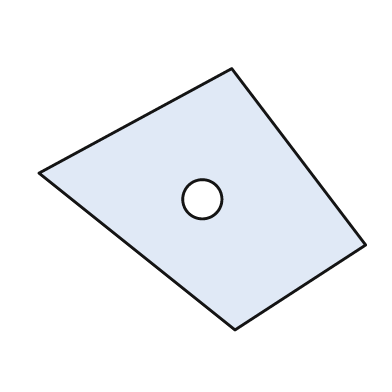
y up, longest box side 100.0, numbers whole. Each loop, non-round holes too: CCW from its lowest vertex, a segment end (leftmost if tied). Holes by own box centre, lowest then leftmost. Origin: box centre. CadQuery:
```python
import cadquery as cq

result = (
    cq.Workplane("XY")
    .moveTo(10.0, -40.0)
    .lineTo(50.0, -14.0)
    .lineTo(9.0, 40.0)
    .lineTo(-50.0, 8.0)
    .close()
    .moveTo(0.0, 0.0)
    .circle(6.0)
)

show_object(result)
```